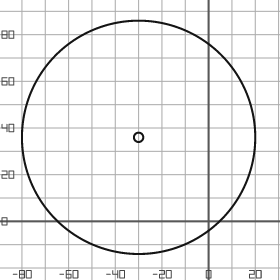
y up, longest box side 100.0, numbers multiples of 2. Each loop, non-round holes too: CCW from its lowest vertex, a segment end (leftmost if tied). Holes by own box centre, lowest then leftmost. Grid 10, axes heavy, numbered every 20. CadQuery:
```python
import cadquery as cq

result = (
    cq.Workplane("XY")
    .moveTo(-30.0, 36.0)
    .circle(50.0)
    .moveTo(-30.0, 36.0)
    .circle(2.0)
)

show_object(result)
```